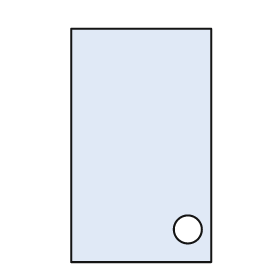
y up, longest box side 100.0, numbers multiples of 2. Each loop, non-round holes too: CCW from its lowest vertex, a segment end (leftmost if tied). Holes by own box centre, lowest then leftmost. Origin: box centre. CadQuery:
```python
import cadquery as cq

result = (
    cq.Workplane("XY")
    .moveTo(-30.0, -50.0)
    .lineTo(30.0, -50.0)
    .lineTo(30.0, 50.0)
    .lineTo(-30.0, 50.0)
    .close()
    .moveTo(20.0, -36.0)
    .circle(6.0)
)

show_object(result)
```